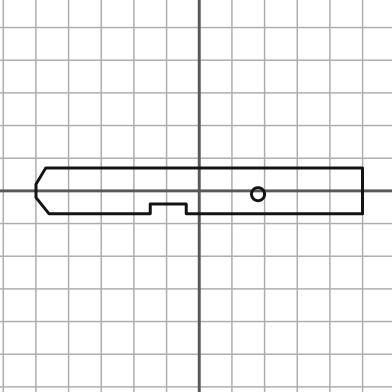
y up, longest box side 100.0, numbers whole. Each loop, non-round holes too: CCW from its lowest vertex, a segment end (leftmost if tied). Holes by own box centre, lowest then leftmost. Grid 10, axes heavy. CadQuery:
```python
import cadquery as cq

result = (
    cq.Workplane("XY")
    .moveTo(-46.0, -7.0)
    .lineTo(-15.0, -7.0)
    .lineTo(-15.0, -4.0)
    .lineTo(-4.0, -4.0)
    .lineTo(-4.0, -7.0)
    .lineTo(50.0, -7.0)
    .lineTo(50.0, 7.0)
    .lineTo(-47.0, 7.0)
    .lineTo(-50.0, 2.0)
    .lineTo(-50.0, -2.0)
    .close()
    .moveTo(18.0, -1.0)
    .circle(2.0)
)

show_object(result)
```